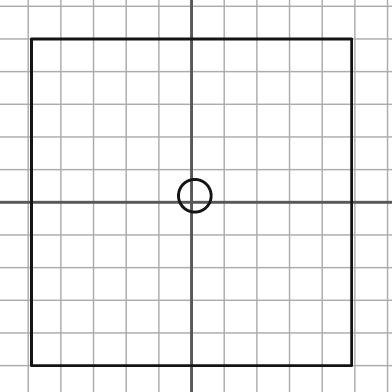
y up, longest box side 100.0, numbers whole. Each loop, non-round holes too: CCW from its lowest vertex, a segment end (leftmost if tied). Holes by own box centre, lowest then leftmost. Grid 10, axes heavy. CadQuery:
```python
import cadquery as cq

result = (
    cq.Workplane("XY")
    .moveTo(-49.0, -50.0)
    .lineTo(49.0, -50.0)
    .lineTo(49.0, 50.0)
    .lineTo(-49.0, 50.0)
    .close()
    .moveTo(1.0, 2.0)
    .circle(5.0)
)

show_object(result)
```